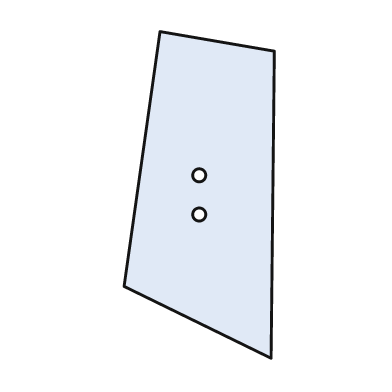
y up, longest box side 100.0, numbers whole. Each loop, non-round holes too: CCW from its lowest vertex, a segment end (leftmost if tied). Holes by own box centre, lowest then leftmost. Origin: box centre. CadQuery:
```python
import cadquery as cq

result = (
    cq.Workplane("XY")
    .moveTo(22.0, -50.0)
    .lineTo(23.0, 44.0)
    .lineTo(-12.0, 50.0)
    .lineTo(-23.0, -28.0)
    .close()
    .moveTo(0.0, -6.0)
    .circle(2.0)
    .moveTo(0.0, 6.0)
    .circle(2.0)
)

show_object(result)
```